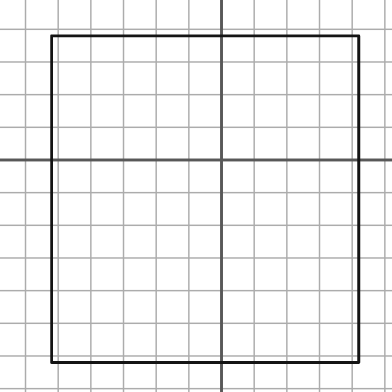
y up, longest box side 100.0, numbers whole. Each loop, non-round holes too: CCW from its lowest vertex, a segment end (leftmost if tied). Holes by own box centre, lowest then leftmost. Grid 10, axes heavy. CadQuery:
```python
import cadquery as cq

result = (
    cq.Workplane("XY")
    .moveTo(-52.0, -62.0)
    .lineTo(42.0, -62.0)
    .lineTo(42.0, 38.0)
    .lineTo(-52.0, 38.0)
    .close()
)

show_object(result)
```